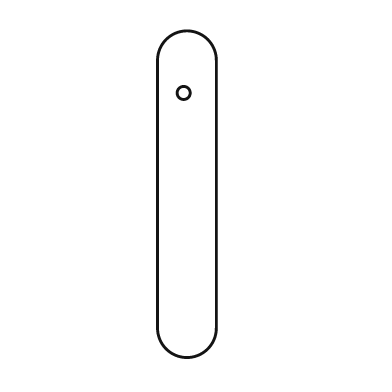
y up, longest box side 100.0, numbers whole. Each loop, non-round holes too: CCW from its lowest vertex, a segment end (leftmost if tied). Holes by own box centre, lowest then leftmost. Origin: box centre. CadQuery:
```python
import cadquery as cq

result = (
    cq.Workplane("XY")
    .moveTo(-9.0, -41.0)
    .threePointArc((0.0, -50.0), (9.0, -41.0))
    .lineTo(9.0, 41.0)
    .threePointArc((0.0, 50.0), (-9.0, 41.0))
    .close()
    .moveTo(-1.0, 31.0)
    .circle(2.0)
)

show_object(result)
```